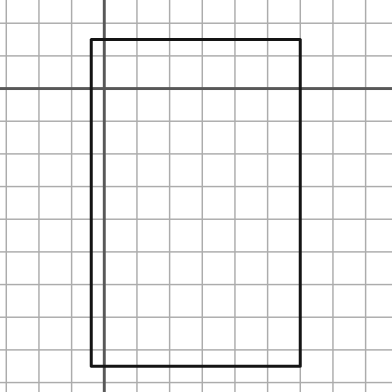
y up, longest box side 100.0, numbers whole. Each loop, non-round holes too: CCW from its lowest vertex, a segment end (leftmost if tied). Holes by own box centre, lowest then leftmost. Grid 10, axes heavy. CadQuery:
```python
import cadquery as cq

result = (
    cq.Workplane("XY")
    .moveTo(-4.0, -85.0)
    .lineTo(60.0, -85.0)
    .lineTo(60.0, 15.0)
    .lineTo(-4.0, 15.0)
    .close()
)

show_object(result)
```